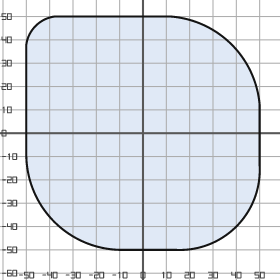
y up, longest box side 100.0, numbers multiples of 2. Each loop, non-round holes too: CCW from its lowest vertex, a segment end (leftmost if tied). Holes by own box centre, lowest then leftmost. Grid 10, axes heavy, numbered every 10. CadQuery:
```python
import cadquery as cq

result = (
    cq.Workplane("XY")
    .moveTo(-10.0, -50.0)
    .lineTo(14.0, -50.0)
    .threePointArc((40.0, -40.0), (50.0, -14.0))
    .lineTo(50.0, 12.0)
    .threePointArc((38.0, 38.0), (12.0, 50.0))
    .lineTo(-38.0, 50.0)
    .threePointArc((-46.0, 46.0), (-50.0, 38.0))
    .lineTo(-50.0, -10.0)
    .threePointArc((-38.0, -38.0), (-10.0, -50.0))
    .close()
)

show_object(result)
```